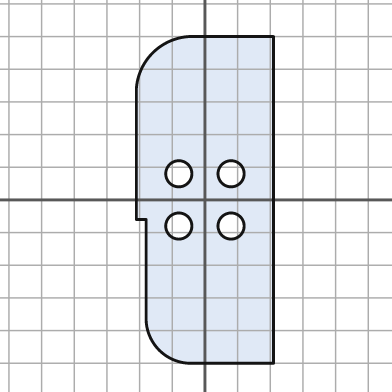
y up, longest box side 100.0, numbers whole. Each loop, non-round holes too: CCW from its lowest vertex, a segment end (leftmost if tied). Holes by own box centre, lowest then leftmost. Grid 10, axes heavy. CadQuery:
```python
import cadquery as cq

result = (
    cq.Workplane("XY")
    .moveTo(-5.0, -50.0)
    .lineTo(21.0, -50.0)
    .lineTo(21.0, 50.0)
    .lineTo(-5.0, 50.0)
    .threePointArc((-16.0, 45.0), (-21.0, 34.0))
    .lineTo(-21.0, -6.0)
    .lineTo(-18.0, -6.0)
    .lineTo(-18.0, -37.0)
    .threePointArc((-14.0, -46.0), (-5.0, -50.0))
    .close()
    .moveTo(-8.0, -8.0)
    .circle(4.0)
    .moveTo(8.0, -8.0)
    .circle(4.0)
    .moveTo(-8.0, 8.0)
    .circle(4.0)
    .moveTo(8.0, 8.0)
    .circle(4.0)
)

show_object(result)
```